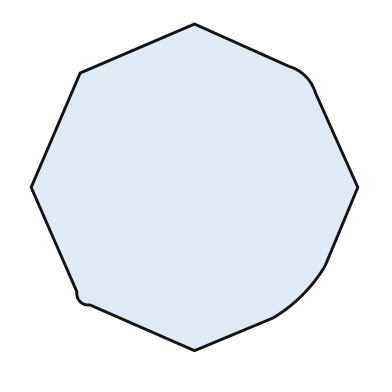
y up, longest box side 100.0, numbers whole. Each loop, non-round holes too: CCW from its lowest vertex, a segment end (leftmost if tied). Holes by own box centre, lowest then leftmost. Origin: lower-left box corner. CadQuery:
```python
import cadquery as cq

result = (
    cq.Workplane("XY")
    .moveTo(50.0, 0.0)
    .lineTo(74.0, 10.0)
    .threePointArc((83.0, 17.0), (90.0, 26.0))
    .lineTo(100.0, 50.0)
    .lineTo(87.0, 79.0)
    .threePointArc((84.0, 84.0), (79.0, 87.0))
    .lineTo(50.0, 100.0)
    .lineTo(15.0, 85.0)
    .lineTo(0.0, 50.0)
    .lineTo(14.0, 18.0)
    .threePointArc((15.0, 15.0), (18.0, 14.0))
    .close()
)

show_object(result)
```